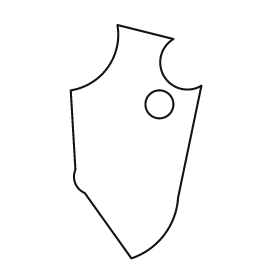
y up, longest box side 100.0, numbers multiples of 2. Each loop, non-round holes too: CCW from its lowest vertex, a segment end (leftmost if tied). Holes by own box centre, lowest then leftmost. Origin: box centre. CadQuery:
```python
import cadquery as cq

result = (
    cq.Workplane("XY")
    .moveTo(-2.0, -50.0)
    .threePointArc((12.0, -40.0), (18.0, -24.0))
    .lineTo(28.0, 24.0)
    .threePointArc((12.0, 28.0), (16.0, 44.0))
    .lineTo(-8.0, 50.0)
    .threePointArc((-12.0, 32.0), (-28.0, 22.0))
    .lineTo(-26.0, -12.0)
    .threePointArc((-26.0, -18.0), (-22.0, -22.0))
    .close()
    .moveTo(10.0, 16.0)
    .circle(6.0)
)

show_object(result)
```